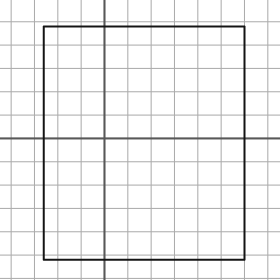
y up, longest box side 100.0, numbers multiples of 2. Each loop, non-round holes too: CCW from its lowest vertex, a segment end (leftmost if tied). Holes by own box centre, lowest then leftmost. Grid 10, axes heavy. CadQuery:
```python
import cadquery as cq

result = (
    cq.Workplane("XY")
    .moveTo(-26.0, -52.0)
    .lineTo(60.0, -52.0)
    .lineTo(60.0, 48.0)
    .lineTo(-26.0, 48.0)
    .close()
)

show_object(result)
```